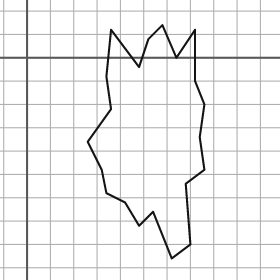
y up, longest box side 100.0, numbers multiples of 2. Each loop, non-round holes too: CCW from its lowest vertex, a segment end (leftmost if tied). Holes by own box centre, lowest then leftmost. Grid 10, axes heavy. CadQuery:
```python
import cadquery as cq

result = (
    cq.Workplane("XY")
    .moveTo(62.0, -86.0)
    .lineTo(70.0, -80.0)
    .lineTo(68.0, -54.0)
    .lineTo(76.0, -48.0)
    .lineTo(74.0, -34.0)
    .lineTo(76.0, -20.0)
    .lineTo(72.0, -10.0)
    .lineTo(72.0, 12.0)
    .lineTo(64.0, 0.0)
    .lineTo(58.0, 14.0)
    .lineTo(52.0, 8.0)
    .lineTo(48.0, -4.0)
    .lineTo(36.0, 12.0)
    .lineTo(34.0, -8.0)
    .lineTo(36.0, -22.0)
    .lineTo(26.0, -36.0)
    .lineTo(32.0, -48.0)
    .lineTo(34.0, -58.0)
    .lineTo(42.0, -62.0)
    .lineTo(48.0, -72.0)
    .lineTo(54.0, -66.0)
    .close()
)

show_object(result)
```